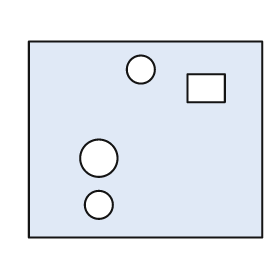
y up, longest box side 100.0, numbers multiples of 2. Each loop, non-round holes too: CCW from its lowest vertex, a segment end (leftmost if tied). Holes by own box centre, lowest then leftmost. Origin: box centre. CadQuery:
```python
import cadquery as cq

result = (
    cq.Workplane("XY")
    .moveTo(-50.0, -42.0)
    .lineTo(50.0, -42.0)
    .lineTo(50.0, 42.0)
    .lineTo(-50.0, 42.0)
    .close()
    .moveTo(-20.0, -28.0)
    .circle(6.0)
    .moveTo(-20.0, -8.0)
    .circle(8.0)
    .moveTo(18.0, 16.0)
    .lineTo(34.0, 16.0)
    .lineTo(34.0, 28.0)
    .lineTo(18.0, 28.0)
    .close()
    .moveTo(-2.0, 30.0)
    .circle(6.0)
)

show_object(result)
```